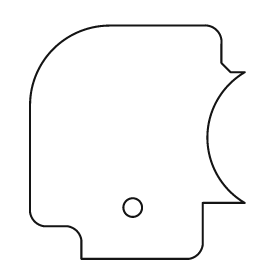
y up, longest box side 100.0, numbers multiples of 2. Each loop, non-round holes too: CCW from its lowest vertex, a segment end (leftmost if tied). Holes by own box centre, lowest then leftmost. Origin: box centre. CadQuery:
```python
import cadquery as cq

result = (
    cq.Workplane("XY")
    .moveTo(-24.0, -50.0)
    .lineTo(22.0, -50.0)
    .threePointArc((26.0, -48.0), (28.0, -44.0))
    .lineTo(28.0, -26.0)
    .lineTo(46.0, -26.0)
    .threePointArc((30.0, 2.0), (46.0, 30.0))
    .lineTo(40.0, 30.0)
    .lineTo(36.0, 34.0)
    .lineTo(36.0, 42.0)
    .threePointArc((34.0, 48.0), (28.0, 50.0))
    .lineTo(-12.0, 50.0)
    .threePointArc((-36.0, 40.0), (-46.0, 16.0))
    .lineTo(-46.0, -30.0)
    .threePointArc((-44.0, -34.0), (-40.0, -36.0))
    .lineTo(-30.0, -36.0)
    .threePointArc((-26.0, -38.0), (-24.0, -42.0))
    .close()
    .moveTo(-2.0, -28.0)
    .circle(4.0)
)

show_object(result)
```